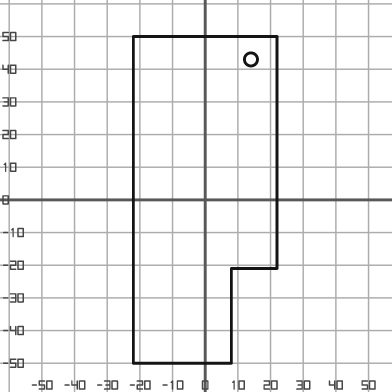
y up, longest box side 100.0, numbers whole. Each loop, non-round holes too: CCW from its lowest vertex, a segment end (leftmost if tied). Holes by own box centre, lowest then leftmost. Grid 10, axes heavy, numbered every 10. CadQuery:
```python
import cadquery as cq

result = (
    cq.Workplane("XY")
    .moveTo(-22.0, -50.0)
    .lineTo(8.0, -50.0)
    .lineTo(8.0, -21.0)
    .lineTo(22.0, -21.0)
    .lineTo(22.0, 50.0)
    .lineTo(-22.0, 50.0)
    .close()
    .moveTo(14.0, 43.0)
    .circle(2.0)
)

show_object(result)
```